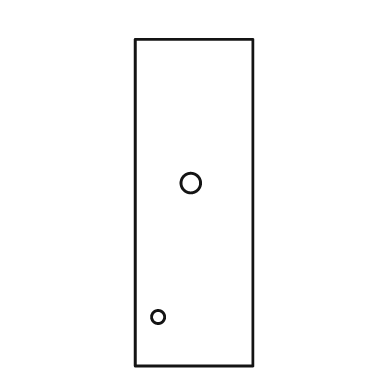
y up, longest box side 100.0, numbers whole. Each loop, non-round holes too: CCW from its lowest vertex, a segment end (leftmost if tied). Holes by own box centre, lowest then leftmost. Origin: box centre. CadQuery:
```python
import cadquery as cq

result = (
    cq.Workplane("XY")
    .moveTo(-18.0, -50.0)
    .lineTo(18.0, -50.0)
    .lineTo(18.0, 50.0)
    .lineTo(-18.0, 50.0)
    .close()
    .moveTo(-11.0, -35.0)
    .circle(2.0)
    .moveTo(-1.0, 6.0)
    .circle(3.0)
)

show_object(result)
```